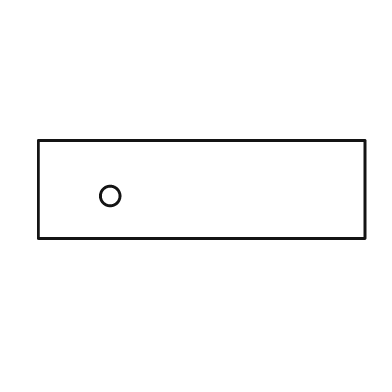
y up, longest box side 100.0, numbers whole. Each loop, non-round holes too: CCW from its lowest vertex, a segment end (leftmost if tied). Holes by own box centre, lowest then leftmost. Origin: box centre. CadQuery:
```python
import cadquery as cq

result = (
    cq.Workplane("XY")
    .moveTo(-50.0, -15.0)
    .lineTo(50.0, -15.0)
    .lineTo(50.0, 15.0)
    .lineTo(-50.0, 15.0)
    .close()
    .moveTo(-28.0, -2.0)
    .circle(3.0)
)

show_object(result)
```